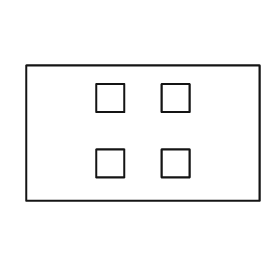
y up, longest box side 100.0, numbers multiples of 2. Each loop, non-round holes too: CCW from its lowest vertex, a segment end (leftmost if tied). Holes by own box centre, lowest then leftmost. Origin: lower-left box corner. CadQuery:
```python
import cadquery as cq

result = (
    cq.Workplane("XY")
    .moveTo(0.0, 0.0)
    .lineTo(100.0, 0.0)
    .lineTo(100.0, 58.0)
    .lineTo(0.0, 58.0)
    .close()
    .moveTo(30.0, 10.0)
    .lineTo(42.0, 10.0)
    .lineTo(42.0, 22.0)
    .lineTo(30.0, 22.0)
    .close()
    .moveTo(58.0, 10.0)
    .lineTo(70.0, 10.0)
    .lineTo(70.0, 22.0)
    .lineTo(58.0, 22.0)
    .close()
    .moveTo(30.0, 38.0)
    .lineTo(42.0, 38.0)
    .lineTo(42.0, 50.0)
    .lineTo(30.0, 50.0)
    .close()
    .moveTo(58.0, 38.0)
    .lineTo(70.0, 38.0)
    .lineTo(70.0, 50.0)
    .lineTo(58.0, 50.0)
    .close()
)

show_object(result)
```